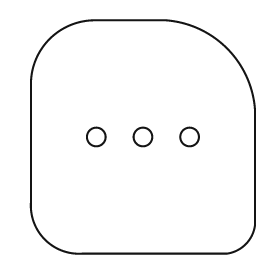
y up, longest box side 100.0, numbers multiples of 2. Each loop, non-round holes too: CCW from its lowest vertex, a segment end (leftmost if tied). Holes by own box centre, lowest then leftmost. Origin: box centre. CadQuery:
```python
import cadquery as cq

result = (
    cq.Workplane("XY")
    .moveTo(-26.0, -50.0)
    .lineTo(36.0, -50.0)
    .threePointArc((44.0, -46.0), (48.0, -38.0))
    .lineTo(48.0, 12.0)
    .threePointArc((36.0, 38.0), (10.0, 50.0))
    .lineTo(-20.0, 50.0)
    .threePointArc((-40.0, 42.0), (-48.0, 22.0))
    .lineTo(-48.0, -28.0)
    .threePointArc((-42.0, -44.0), (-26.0, -50.0))
    .close()
    .moveTo(-20.0, 0.0)
    .circle(4.0)
    .moveTo(0.0, 0.0)
    .circle(4.0)
    .moveTo(20.0, 0.0)
    .circle(4.0)
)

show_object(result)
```